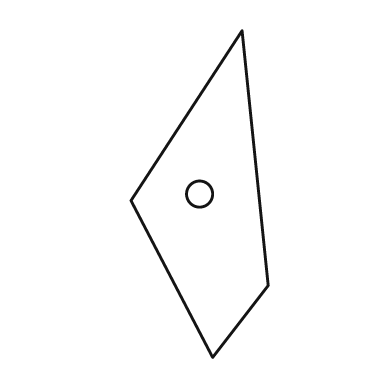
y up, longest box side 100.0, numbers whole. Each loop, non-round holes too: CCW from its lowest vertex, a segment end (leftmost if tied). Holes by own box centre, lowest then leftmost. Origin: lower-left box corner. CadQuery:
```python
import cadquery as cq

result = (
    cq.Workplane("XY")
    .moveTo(25.0, 0.0)
    .lineTo(42.0, 22.0)
    .lineTo(34.0, 100.0)
    .lineTo(0.0, 48.0)
    .close()
    .moveTo(21.0, 50.0)
    .circle(4.0)
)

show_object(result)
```